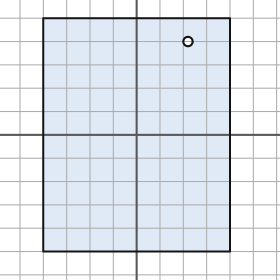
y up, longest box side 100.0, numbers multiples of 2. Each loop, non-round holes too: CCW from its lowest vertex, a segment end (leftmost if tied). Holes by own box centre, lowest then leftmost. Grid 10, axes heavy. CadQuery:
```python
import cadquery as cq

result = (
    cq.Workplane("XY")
    .moveTo(-40.0, -50.0)
    .lineTo(40.0, -50.0)
    .lineTo(40.0, 50.0)
    .lineTo(-40.0, 50.0)
    .close()
    .moveTo(22.0, 40.0)
    .circle(2.0)
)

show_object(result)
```